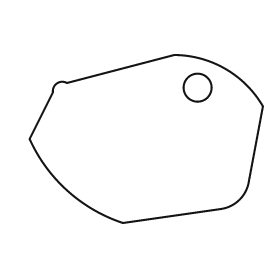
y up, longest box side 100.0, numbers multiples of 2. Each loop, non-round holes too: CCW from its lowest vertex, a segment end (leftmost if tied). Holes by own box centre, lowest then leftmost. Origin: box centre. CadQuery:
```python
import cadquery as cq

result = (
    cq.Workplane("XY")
    .moveTo(-10.0, -36.0)
    .lineTo(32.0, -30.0)
    .threePointArc((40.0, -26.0), (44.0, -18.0))
    .lineTo(50.0, 14.0)
    .threePointArc((34.0, 30.0), (12.0, 36.0))
    .lineTo(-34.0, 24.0)
    .threePointArc((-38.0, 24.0), (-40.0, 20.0))
    .lineTo(-50.0, 0.0)
    .threePointArc((-34.0, -22.0), (-10.0, -36.0))
    .close()
    .moveTo(22.0, 22.0)
    .circle(6.0)
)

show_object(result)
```